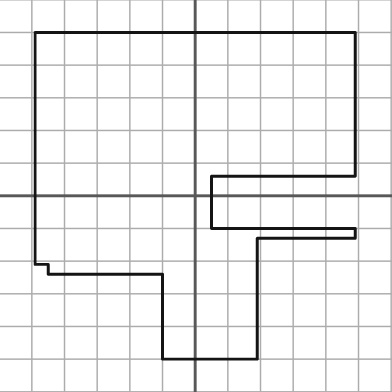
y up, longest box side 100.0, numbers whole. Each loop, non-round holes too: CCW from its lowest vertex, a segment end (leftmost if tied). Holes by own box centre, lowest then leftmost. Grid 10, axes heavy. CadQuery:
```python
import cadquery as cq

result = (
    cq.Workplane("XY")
    .moveTo(-10.0, -50.0)
    .lineTo(19.0, -50.0)
    .lineTo(19.0, -13.0)
    .lineTo(49.0, -13.0)
    .lineTo(49.0, -10.0)
    .lineTo(5.0, -10.0)
    .lineTo(5.0, 6.0)
    .lineTo(49.0, 6.0)
    .lineTo(49.0, 50.0)
    .lineTo(-49.0, 50.0)
    .lineTo(-49.0, -21.0)
    .lineTo(-45.0, -21.0)
    .lineTo(-45.0, -24.0)
    .lineTo(-10.0, -24.0)
    .close()
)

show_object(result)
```